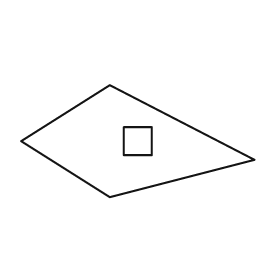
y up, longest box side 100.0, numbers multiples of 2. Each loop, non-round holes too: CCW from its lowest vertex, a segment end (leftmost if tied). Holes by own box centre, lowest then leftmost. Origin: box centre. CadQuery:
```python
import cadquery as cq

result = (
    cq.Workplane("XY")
    .moveTo(-12.0, -24.0)
    .lineTo(50.0, -8.0)
    .lineTo(-12.0, 24.0)
    .lineTo(-50.0, 0.0)
    .close()
    .moveTo(-6.0, -6.0)
    .lineTo(6.0, -6.0)
    .lineTo(6.0, 6.0)
    .lineTo(-6.0, 6.0)
    .close()
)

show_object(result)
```